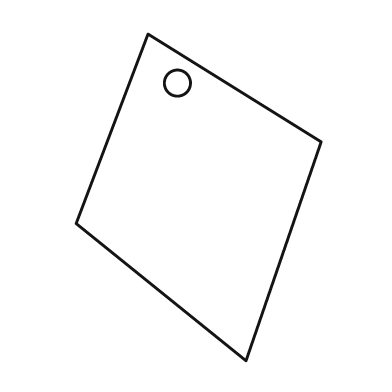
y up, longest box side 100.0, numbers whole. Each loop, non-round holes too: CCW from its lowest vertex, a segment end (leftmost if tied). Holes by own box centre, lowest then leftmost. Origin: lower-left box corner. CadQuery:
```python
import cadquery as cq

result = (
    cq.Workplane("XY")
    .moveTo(52.0, 0.0)
    .lineTo(75.0, 67.0)
    .lineTo(22.0, 100.0)
    .lineTo(0.0, 42.0)
    .close()
    .moveTo(31.0, 85.0)
    .circle(4.0)
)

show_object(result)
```